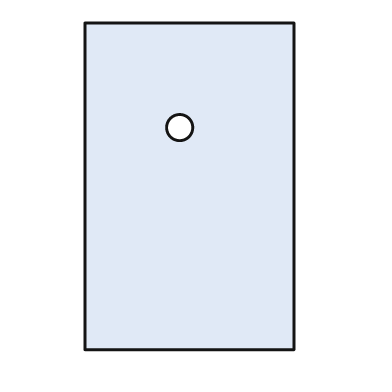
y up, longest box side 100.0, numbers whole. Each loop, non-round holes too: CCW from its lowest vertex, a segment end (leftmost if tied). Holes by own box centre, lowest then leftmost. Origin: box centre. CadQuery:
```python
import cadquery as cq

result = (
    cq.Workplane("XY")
    .moveTo(-32.0, -50.0)
    .lineTo(32.0, -50.0)
    .lineTo(32.0, 50.0)
    .lineTo(-32.0, 50.0)
    .close()
    .moveTo(-3.0, 18.0)
    .circle(4.0)
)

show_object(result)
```